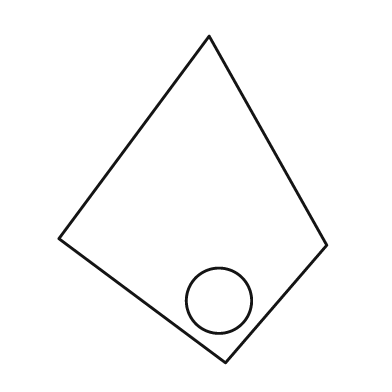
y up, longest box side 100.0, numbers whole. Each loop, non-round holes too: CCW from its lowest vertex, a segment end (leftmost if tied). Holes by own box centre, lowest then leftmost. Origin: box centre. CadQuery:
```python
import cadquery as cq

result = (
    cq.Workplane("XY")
    .moveTo(10.0, -50.0)
    .lineTo(41.0, -14.0)
    .lineTo(5.0, 50.0)
    .lineTo(-41.0, -12.0)
    .close()
    .moveTo(8.0, -31.0)
    .circle(10.0)
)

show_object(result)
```